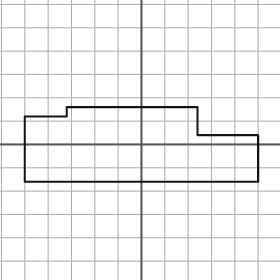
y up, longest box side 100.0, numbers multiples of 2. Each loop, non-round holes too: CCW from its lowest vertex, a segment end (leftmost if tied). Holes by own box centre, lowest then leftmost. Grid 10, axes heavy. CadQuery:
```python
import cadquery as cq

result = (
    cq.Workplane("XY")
    .moveTo(-50.0, -16.0)
    .lineTo(50.0, -16.0)
    .lineTo(50.0, 4.0)
    .lineTo(24.0, 4.0)
    .lineTo(24.0, 16.0)
    .lineTo(-32.0, 16.0)
    .lineTo(-32.0, 12.0)
    .lineTo(-50.0, 12.0)
    .close()
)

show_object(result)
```